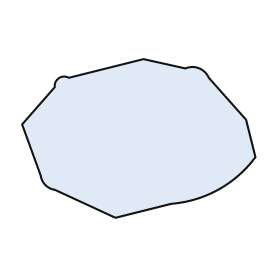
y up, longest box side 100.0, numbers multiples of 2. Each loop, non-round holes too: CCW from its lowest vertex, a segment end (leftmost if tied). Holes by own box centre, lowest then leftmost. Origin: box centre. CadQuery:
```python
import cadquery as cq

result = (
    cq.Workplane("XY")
    .moveTo(-10.0, -34.0)
    .lineTo(14.0, -28.0)
    .threePointArc((34.0, -22.0), (50.0, -8.0))
    .lineTo(46.0, 8.0)
    .lineTo(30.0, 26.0)
    .threePointArc((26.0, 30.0), (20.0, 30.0))
    .lineTo(2.0, 34.0)
    .lineTo(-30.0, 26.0)
    .threePointArc((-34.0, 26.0), (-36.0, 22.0))
    .lineTo(-50.0, 6.0)
    .lineTo(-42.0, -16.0)
    .threePointArc((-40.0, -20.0), (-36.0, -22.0))
    .close()
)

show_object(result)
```